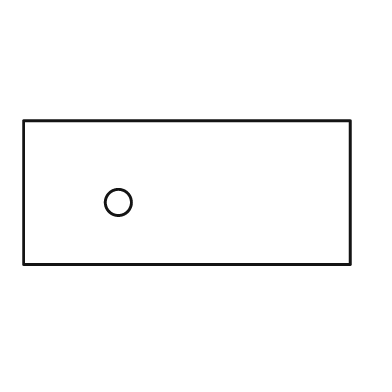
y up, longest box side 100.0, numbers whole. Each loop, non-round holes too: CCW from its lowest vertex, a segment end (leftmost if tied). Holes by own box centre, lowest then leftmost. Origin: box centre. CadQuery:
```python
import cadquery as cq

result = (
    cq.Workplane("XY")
    .moveTo(-50.0, -22.0)
    .lineTo(50.0, -22.0)
    .lineTo(50.0, 22.0)
    .lineTo(-50.0, 22.0)
    .close()
    .moveTo(-21.0, -3.0)
    .circle(4.0)
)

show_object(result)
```